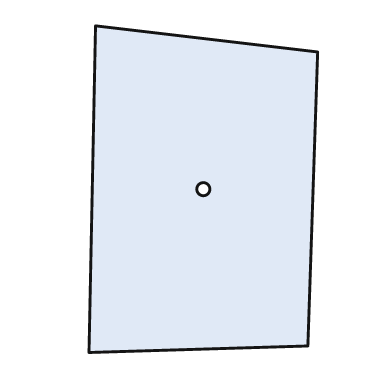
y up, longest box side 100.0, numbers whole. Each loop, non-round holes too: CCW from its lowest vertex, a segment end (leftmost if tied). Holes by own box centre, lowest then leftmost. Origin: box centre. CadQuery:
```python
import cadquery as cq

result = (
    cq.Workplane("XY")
    .moveTo(-35.0, -50.0)
    .lineTo(32.0, -48.0)
    .lineTo(35.0, 42.0)
    .lineTo(-33.0, 50.0)
    .close()
    .moveTo(0.0, 0.0)
    .circle(2.0)
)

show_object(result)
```